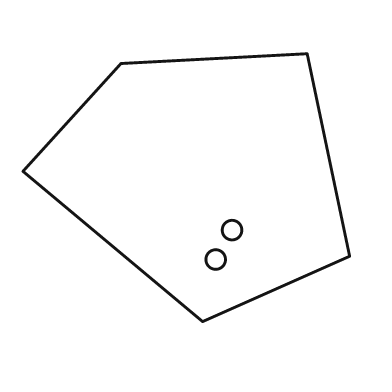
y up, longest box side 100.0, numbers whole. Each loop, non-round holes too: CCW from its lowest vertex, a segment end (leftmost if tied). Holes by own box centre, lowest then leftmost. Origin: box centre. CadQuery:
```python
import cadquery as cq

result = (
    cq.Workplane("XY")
    .moveTo(5.0, -41.0)
    .lineTo(50.0, -21.0)
    .lineTo(37.0, 41.0)
    .lineTo(-20.0, 38.0)
    .lineTo(-50.0, 5.0)
    .close()
    .moveTo(9.0, -22.0)
    .circle(3.0)
    .moveTo(14.0, -13.0)
    .circle(3.0)
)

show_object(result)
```